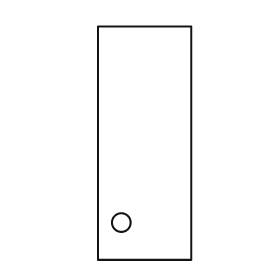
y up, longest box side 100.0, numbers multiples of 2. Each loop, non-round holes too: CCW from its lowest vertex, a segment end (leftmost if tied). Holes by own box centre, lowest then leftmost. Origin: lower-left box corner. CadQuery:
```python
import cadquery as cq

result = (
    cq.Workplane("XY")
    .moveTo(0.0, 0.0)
    .lineTo(40.0, 0.0)
    .lineTo(40.0, 100.0)
    .lineTo(0.0, 100.0)
    .close()
    .moveTo(10.0, 16.0)
    .circle(4.0)
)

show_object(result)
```